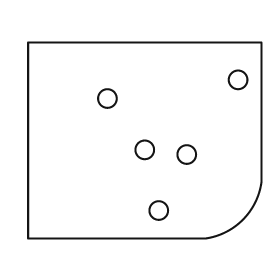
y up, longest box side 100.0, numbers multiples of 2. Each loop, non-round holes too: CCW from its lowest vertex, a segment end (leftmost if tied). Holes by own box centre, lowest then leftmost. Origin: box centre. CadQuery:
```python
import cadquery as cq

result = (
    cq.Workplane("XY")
    .moveTo(-50.0, -42.0)
    .lineTo(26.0, -42.0)
    .threePointArc((42.0, -34.0), (50.0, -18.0))
    .lineTo(50.0, 42.0)
    .lineTo(-50.0, 42.0)
    .close()
    .moveTo(6.0, -30.0)
    .circle(4.0)
    .moveTo(18.0, -6.0)
    .circle(4.0)
    .moveTo(0.0, -4.0)
    .circle(4.0)
    .moveTo(-16.0, 18.0)
    .circle(4.0)
    .moveTo(40.0, 26.0)
    .circle(4.0)
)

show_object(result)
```